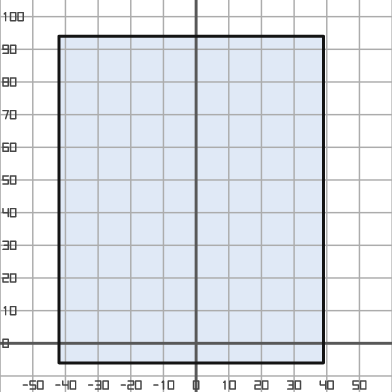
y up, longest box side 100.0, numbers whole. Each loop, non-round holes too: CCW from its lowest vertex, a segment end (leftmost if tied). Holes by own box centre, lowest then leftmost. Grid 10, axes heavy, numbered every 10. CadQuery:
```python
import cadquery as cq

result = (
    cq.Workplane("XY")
    .moveTo(-42.0, -6.0)
    .lineTo(39.0, -6.0)
    .lineTo(39.0, 94.0)
    .lineTo(-42.0, 94.0)
    .close()
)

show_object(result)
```